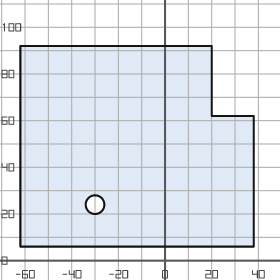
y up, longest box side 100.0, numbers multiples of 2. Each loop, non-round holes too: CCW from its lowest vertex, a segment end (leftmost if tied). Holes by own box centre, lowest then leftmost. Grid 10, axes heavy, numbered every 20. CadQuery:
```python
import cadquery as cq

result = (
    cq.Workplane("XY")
    .moveTo(-62.0, 6.0)
    .lineTo(38.0, 6.0)
    .lineTo(38.0, 62.0)
    .lineTo(20.0, 62.0)
    .lineTo(20.0, 92.0)
    .lineTo(-62.0, 92.0)
    .close()
    .moveTo(-30.0, 24.0)
    .circle(4.0)
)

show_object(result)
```